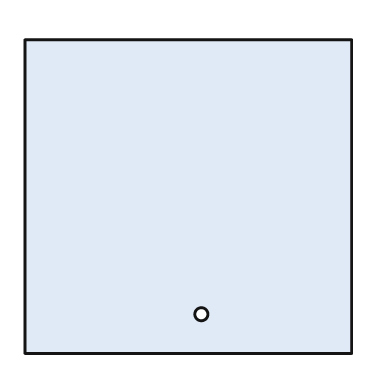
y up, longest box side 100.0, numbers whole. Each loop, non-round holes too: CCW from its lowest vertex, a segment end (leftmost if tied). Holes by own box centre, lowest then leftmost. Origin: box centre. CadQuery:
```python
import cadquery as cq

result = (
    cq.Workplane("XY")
    .moveTo(-50.0, -48.0)
    .lineTo(50.0, -48.0)
    .lineTo(50.0, 48.0)
    .lineTo(-50.0, 48.0)
    .close()
    .moveTo(4.0, -36.0)
    .circle(2.0)
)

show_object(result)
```